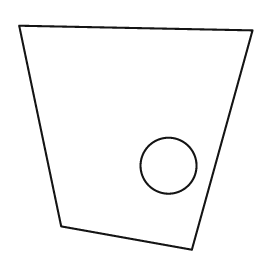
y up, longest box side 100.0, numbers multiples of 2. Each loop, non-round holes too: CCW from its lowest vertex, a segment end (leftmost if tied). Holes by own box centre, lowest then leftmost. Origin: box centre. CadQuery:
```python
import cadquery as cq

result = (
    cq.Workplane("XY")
    .moveTo(24.0, -48.0)
    .lineTo(50.0, 46.0)
    .lineTo(-50.0, 48.0)
    .lineTo(-32.0, -38.0)
    .close()
    .moveTo(14.0, -12.0)
    .circle(12.0)
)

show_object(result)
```